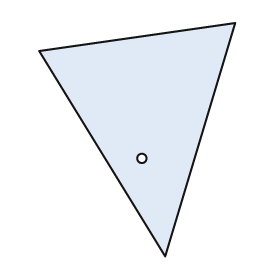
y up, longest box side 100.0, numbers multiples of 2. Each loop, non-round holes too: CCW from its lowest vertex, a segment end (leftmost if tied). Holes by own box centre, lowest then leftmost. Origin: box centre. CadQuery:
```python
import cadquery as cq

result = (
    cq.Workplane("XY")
    .moveTo(12.0, -50.0)
    .lineTo(42.0, 50.0)
    .lineTo(-42.0, 38.0)
    .close()
    .moveTo(2.0, -8.0)
    .circle(2.0)
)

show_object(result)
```